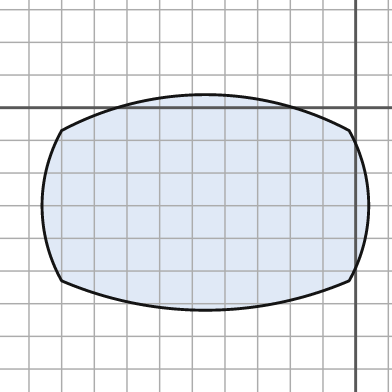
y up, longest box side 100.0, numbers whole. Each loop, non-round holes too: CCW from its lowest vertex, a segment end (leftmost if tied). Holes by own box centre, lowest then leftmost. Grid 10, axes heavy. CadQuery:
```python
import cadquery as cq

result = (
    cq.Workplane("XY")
    .moveTo(-90.0, -53.0)
    .threePointArc((-46.0, -62.0), (-2.0, -53.0))
    .threePointArc((4.0, -30.0), (-2.0, -7.0))
    .threePointArc((-46.0, 4.0), (-90.0, -7.0))
    .threePointArc((-96.0, -30.0), (-90.0, -53.0))
    .close()
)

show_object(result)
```